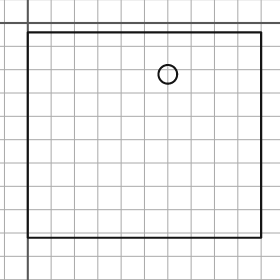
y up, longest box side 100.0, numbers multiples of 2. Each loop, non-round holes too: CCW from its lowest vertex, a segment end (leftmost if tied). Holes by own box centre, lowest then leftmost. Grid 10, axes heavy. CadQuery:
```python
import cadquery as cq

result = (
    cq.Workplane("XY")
    .moveTo(0.0, -92.0)
    .lineTo(100.0, -92.0)
    .lineTo(100.0, -4.0)
    .lineTo(0.0, -4.0)
    .close()
    .moveTo(60.0, -22.0)
    .circle(4.0)
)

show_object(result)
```